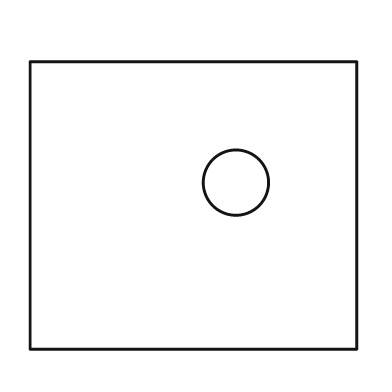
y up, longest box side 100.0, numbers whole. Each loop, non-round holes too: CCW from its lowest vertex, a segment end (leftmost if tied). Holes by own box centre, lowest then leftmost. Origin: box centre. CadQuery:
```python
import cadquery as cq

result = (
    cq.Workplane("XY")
    .moveTo(-50.0, -44.0)
    .lineTo(50.0, -44.0)
    .lineTo(50.0, 44.0)
    .lineTo(-50.0, 44.0)
    .close()
    .moveTo(13.0, 7.0)
    .circle(10.0)
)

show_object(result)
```